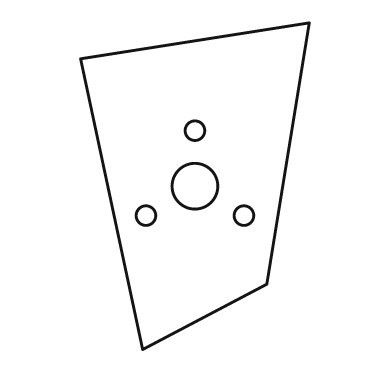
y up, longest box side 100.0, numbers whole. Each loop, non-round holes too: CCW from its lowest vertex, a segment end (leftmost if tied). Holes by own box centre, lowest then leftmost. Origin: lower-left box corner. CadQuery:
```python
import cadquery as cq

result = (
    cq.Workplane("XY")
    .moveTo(19.0, 0.0)
    .lineTo(57.0, 20.0)
    .lineTo(70.0, 100.0)
    .lineTo(0.0, 89.0)
    .close()
    .moveTo(20.0, 41.0)
    .circle(3.0)
    .moveTo(50.0, 41.0)
    .circle(3.0)
    .moveTo(35.0, 50.0)
    .circle(7.0)
    .moveTo(35.0, 67.0)
    .circle(3.0)
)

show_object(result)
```